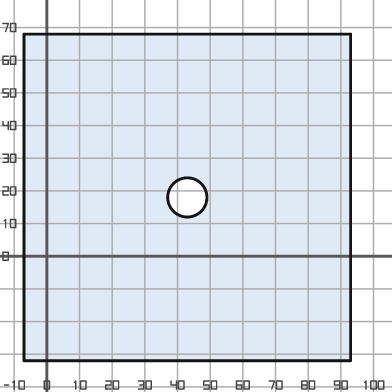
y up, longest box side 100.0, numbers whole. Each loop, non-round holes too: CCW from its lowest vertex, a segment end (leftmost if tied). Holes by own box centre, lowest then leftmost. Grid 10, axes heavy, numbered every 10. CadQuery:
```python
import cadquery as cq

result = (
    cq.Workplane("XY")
    .moveTo(-7.0, -32.0)
    .lineTo(93.0, -32.0)
    .lineTo(93.0, 68.0)
    .lineTo(-7.0, 68.0)
    .close()
    .moveTo(43.0, 18.0)
    .circle(6.0)
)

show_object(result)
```